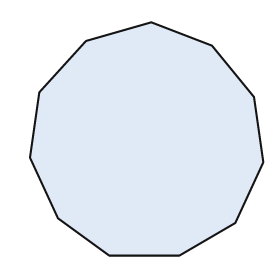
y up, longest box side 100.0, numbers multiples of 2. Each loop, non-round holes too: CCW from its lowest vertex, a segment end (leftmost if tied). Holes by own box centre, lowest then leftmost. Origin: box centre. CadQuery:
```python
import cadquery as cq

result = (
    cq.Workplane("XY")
    .moveTo(-16.0, -50.0)
    .lineTo(14.0, -50.0)
    .lineTo(38.0, -36.0)
    .lineTo(50.0, -10.0)
    .lineTo(46.0, 18.0)
    .lineTo(28.0, 40.0)
    .lineTo(2.0, 50.0)
    .lineTo(-26.0, 42.0)
    .lineTo(-46.0, 20.0)
    .lineTo(-50.0, -8.0)
    .lineTo(-38.0, -34.0)
    .close()
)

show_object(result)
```